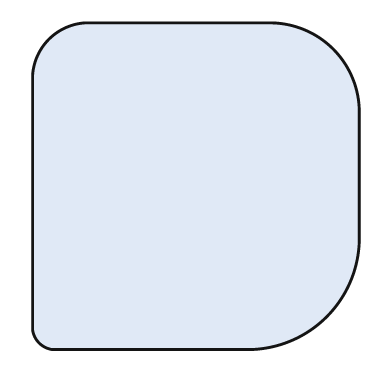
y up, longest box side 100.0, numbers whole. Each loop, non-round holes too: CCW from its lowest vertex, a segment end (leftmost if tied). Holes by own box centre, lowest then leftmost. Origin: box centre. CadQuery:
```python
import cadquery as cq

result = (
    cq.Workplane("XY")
    .moveTo(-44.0, -50.0)
    .lineTo(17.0, -50.0)
    .threePointArc((40.0, -40.0), (50.0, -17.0))
    .lineTo(50.0, 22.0)
    .threePointArc((42.0, 42.0), (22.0, 50.0))
    .lineTo(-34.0, 50.0)
    .threePointArc((-45.0, 45.0), (-50.0, 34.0))
    .lineTo(-50.0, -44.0)
    .threePointArc((-48.0, -48.0), (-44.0, -50.0))
    .close()
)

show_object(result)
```